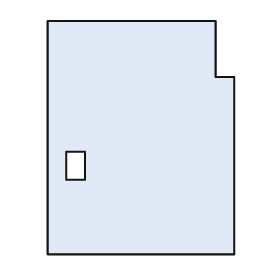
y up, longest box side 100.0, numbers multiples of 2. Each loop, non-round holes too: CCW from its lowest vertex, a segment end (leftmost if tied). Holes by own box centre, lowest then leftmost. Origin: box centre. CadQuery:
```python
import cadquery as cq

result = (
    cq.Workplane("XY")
    .moveTo(-40.0, -50.0)
    .lineTo(40.0, -50.0)
    .lineTo(40.0, 26.0)
    .lineTo(32.0, 26.0)
    .lineTo(32.0, 50.0)
    .lineTo(-40.0, 50.0)
    .close()
    .moveTo(-32.0, -18.0)
    .lineTo(-24.0, -18.0)
    .lineTo(-24.0, -6.0)
    .lineTo(-32.0, -6.0)
    .close()
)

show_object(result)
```